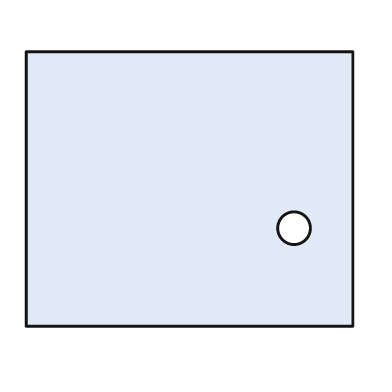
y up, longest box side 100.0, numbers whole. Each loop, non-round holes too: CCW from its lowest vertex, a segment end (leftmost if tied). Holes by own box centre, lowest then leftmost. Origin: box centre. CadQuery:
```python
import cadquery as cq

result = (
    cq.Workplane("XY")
    .moveTo(-50.0, -42.0)
    .lineTo(50.0, -42.0)
    .lineTo(50.0, 42.0)
    .lineTo(-50.0, 42.0)
    .close()
    .moveTo(32.0, -12.0)
    .circle(5.0)
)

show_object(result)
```